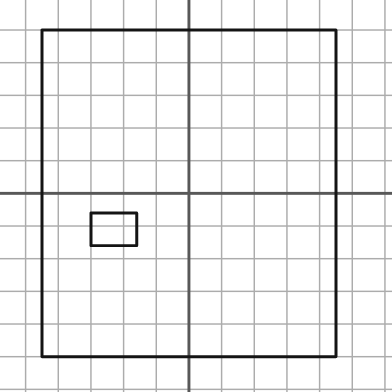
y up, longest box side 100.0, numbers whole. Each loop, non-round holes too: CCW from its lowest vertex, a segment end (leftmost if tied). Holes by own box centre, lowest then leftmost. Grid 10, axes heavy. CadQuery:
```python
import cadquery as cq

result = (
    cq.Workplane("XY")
    .moveTo(-45.0, -50.0)
    .lineTo(45.0, -50.0)
    .lineTo(45.0, 50.0)
    .lineTo(-45.0, 50.0)
    .close()
    .moveTo(-30.0, -16.0)
    .lineTo(-16.0, -16.0)
    .lineTo(-16.0, -6.0)
    .lineTo(-30.0, -6.0)
    .close()
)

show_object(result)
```